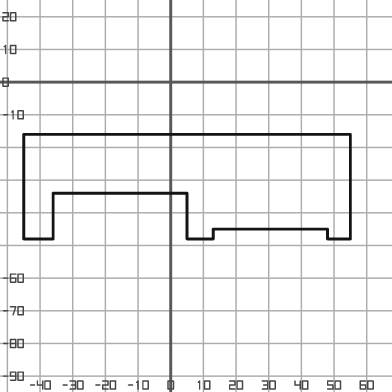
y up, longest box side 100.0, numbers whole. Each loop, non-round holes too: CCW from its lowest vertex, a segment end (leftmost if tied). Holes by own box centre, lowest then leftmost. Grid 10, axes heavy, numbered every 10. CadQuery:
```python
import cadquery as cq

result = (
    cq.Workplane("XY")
    .moveTo(-45.0, -48.0)
    .lineTo(-36.0, -48.0)
    .lineTo(-36.0, -34.0)
    .lineTo(5.0, -34.0)
    .lineTo(5.0, -48.0)
    .lineTo(13.0, -48.0)
    .lineTo(13.0, -45.0)
    .lineTo(48.0, -45.0)
    .lineTo(48.0, -48.0)
    .lineTo(55.0, -48.0)
    .lineTo(55.0, -16.0)
    .lineTo(-45.0, -16.0)
    .close()
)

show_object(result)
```